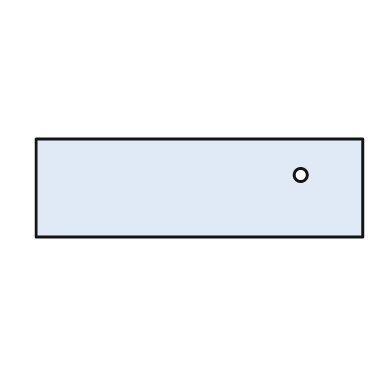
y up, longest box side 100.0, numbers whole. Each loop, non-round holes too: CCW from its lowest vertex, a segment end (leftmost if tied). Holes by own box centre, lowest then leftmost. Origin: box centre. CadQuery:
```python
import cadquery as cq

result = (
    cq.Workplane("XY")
    .moveTo(-50.0, -15.0)
    .lineTo(50.0, -15.0)
    .lineTo(50.0, 15.0)
    .lineTo(-50.0, 15.0)
    .close()
    .moveTo(31.0, 4.0)
    .circle(2.0)
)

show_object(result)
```